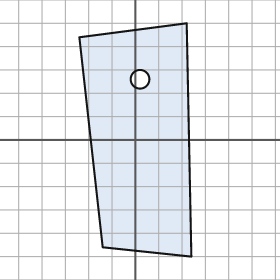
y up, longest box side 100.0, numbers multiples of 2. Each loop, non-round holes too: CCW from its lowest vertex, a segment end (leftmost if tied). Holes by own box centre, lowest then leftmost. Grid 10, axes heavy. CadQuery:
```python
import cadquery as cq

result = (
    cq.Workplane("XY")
    .moveTo(24.0, -50.0)
    .lineTo(22.0, 50.0)
    .lineTo(-24.0, 44.0)
    .lineTo(-14.0, -46.0)
    .close()
    .moveTo(2.0, 26.0)
    .circle(4.0)
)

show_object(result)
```